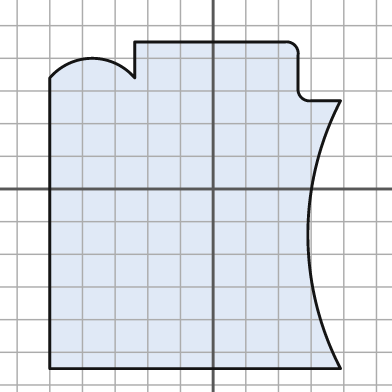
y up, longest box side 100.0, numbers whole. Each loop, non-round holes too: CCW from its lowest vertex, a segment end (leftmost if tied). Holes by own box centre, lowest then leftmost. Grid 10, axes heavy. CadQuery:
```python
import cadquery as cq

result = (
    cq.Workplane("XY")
    .moveTo(-50.0, -55.0)
    .lineTo(39.0, -55.0)
    .threePointArc((29.0, -14.0), (39.0, 27.0))
    .lineTo(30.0, 27.0)
    .threePointArc((27.0, 28.0), (26.0, 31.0))
    .lineTo(26.0, 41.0)
    .threePointArc((25.0, 44.0), (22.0, 45.0))
    .lineTo(-24.0, 45.0)
    .lineTo(-24.0, 34.0)
    .threePointArc((-37.0, 40.0), (-50.0, 34.0))
    .close()
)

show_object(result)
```